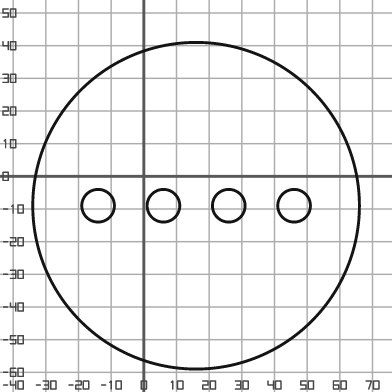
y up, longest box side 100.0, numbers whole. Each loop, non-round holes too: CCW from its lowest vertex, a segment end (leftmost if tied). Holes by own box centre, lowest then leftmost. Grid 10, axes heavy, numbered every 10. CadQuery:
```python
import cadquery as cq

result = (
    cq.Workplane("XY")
    .moveTo(16.0, -9.0)
    .circle(50.0)
    .moveTo(-14.0, -9.0)
    .circle(5.0)
    .moveTo(6.0, -9.0)
    .circle(5.0)
    .moveTo(26.0, -9.0)
    .circle(5.0)
    .moveTo(46.0, -9.0)
    .circle(5.0)
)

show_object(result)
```